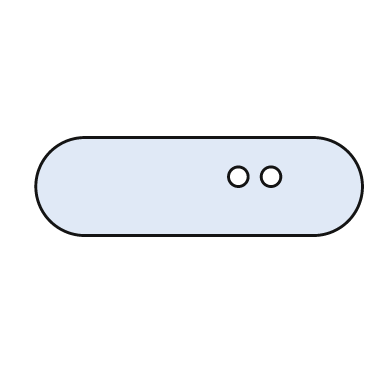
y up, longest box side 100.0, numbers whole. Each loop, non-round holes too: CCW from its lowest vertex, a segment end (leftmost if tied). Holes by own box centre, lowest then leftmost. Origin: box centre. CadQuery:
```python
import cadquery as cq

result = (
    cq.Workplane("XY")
    .moveTo(-35.0, -15.0)
    .lineTo(35.0, -15.0)
    .threePointArc((50.0, 0.0), (35.0, 15.0))
    .lineTo(-35.0, 15.0)
    .threePointArc((-50.0, 0.0), (-35.0, -15.0))
    .close()
    .moveTo(12.0, 3.0)
    .circle(3.0)
    .moveTo(22.0, 3.0)
    .circle(3.0)
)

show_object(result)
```